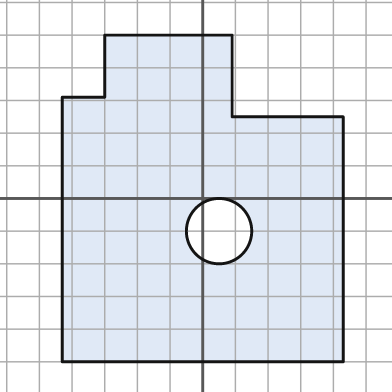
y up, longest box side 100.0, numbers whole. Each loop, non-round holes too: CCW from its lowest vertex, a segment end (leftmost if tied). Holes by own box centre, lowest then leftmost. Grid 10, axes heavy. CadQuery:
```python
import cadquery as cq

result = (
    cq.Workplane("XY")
    .moveTo(-43.0, -50.0)
    .lineTo(43.0, -50.0)
    .lineTo(43.0, 25.0)
    .lineTo(9.0, 25.0)
    .lineTo(9.0, 50.0)
    .lineTo(-30.0, 50.0)
    .lineTo(-30.0, 31.0)
    .lineTo(-43.0, 31.0)
    .close()
    .moveTo(5.0, -10.0)
    .circle(10.0)
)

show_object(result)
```